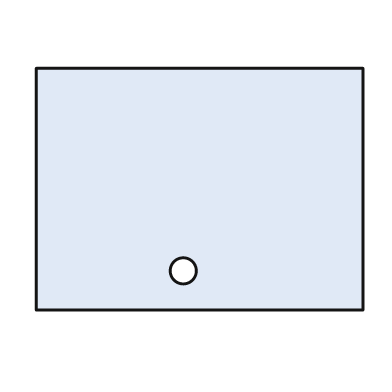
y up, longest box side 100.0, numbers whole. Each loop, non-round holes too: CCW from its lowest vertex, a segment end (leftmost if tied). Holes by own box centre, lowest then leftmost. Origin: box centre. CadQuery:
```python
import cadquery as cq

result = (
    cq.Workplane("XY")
    .moveTo(-50.0, -37.0)
    .lineTo(50.0, -37.0)
    .lineTo(50.0, 37.0)
    .lineTo(-50.0, 37.0)
    .close()
    .moveTo(-5.0, -25.0)
    .circle(4.0)
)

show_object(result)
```